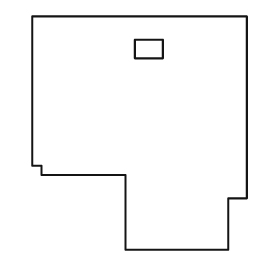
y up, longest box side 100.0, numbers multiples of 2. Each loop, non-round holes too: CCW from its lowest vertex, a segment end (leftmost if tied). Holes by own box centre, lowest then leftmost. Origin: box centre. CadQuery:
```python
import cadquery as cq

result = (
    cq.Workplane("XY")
    .moveTo(-6.0, -50.0)
    .lineTo(38.0, -50.0)
    .lineTo(38.0, -28.0)
    .lineTo(46.0, -28.0)
    .lineTo(46.0, 50.0)
    .lineTo(-46.0, 50.0)
    .lineTo(-46.0, -14.0)
    .lineTo(-42.0, -14.0)
    .lineTo(-42.0, -18.0)
    .lineTo(-6.0, -18.0)
    .close()
    .moveTo(-2.0, 32.0)
    .lineTo(10.0, 32.0)
    .lineTo(10.0, 40.0)
    .lineTo(-2.0, 40.0)
    .close()
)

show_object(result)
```